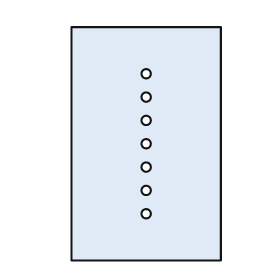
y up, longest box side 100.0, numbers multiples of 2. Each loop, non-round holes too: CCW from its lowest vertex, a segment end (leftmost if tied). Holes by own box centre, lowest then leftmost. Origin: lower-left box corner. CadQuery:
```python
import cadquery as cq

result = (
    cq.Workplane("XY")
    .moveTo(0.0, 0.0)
    .lineTo(64.0, 0.0)
    .lineTo(64.0, 100.0)
    .lineTo(0.0, 100.0)
    .close()
    .moveTo(32.0, 20.0)
    .circle(2.0)
    .moveTo(32.0, 30.0)
    .circle(2.0)
    .moveTo(32.0, 40.0)
    .circle(2.0)
    .moveTo(32.0, 50.0)
    .circle(2.0)
    .moveTo(32.0, 60.0)
    .circle(2.0)
    .moveTo(32.0, 70.0)
    .circle(2.0)
    .moveTo(32.0, 80.0)
    .circle(2.0)
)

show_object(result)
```